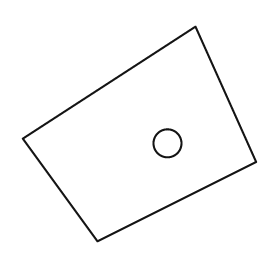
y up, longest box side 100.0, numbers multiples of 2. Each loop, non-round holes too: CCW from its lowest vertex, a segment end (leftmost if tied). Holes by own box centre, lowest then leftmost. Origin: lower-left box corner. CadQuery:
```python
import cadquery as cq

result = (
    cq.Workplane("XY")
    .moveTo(32.0, 0.0)
    .lineTo(100.0, 34.0)
    .lineTo(74.0, 92.0)
    .lineTo(0.0, 44.0)
    .close()
    .moveTo(62.0, 42.0)
    .circle(6.0)
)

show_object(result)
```